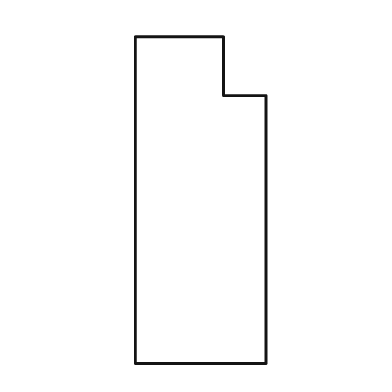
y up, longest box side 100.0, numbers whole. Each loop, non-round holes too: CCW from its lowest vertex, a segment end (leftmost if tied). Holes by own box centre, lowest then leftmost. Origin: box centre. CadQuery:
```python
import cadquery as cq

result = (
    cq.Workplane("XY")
    .moveTo(-20.0, -50.0)
    .lineTo(20.0, -50.0)
    .lineTo(20.0, 32.0)
    .lineTo(7.0, 32.0)
    .lineTo(7.0, 50.0)
    .lineTo(-20.0, 50.0)
    .close()
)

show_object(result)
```